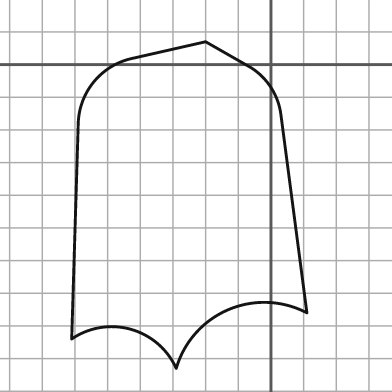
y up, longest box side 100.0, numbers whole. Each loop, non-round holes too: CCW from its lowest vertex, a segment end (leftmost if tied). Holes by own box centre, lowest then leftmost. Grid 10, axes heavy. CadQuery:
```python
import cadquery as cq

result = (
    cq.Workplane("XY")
    .moveTo(-29.0, -93.0)
    .threePointArc((-13.0, -75.0), (11.0, -76.0))
    .lineTo(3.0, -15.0)
    .threePointArc((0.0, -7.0), (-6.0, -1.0))
    .lineTo(-20.0, 7.0)
    .lineTo(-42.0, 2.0)
    .threePointArc((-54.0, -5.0), (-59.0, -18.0))
    .lineTo(-61.0, -84.0)
    .threePointArc((-43.0, -81.0), (-29.0, -93.0))
    .close()
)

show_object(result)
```